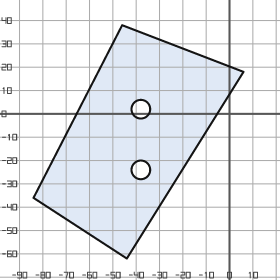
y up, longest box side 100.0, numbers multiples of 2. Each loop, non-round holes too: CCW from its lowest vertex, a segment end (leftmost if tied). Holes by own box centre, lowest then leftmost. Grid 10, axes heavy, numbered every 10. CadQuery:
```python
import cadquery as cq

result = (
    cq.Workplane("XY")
    .moveTo(-44.0, -62.0)
    .lineTo(6.0, 18.0)
    .lineTo(-46.0, 38.0)
    .lineTo(-84.0, -36.0)
    .close()
    .moveTo(-38.0, -24.0)
    .circle(4.0)
    .moveTo(-38.0, 2.0)
    .circle(4.0)
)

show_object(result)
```